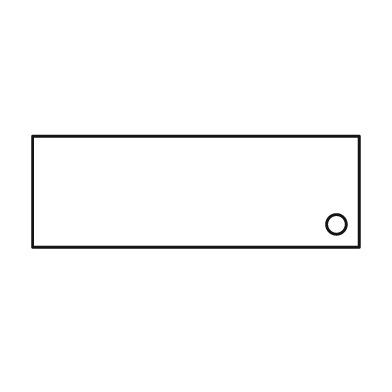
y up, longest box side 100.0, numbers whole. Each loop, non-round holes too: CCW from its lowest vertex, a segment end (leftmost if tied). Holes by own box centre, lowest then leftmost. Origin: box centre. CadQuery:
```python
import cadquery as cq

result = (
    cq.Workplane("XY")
    .moveTo(-50.0, -17.0)
    .lineTo(50.0, -17.0)
    .lineTo(50.0, 17.0)
    .lineTo(-50.0, 17.0)
    .close()
    .moveTo(43.0, -10.0)
    .circle(3.0)
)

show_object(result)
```